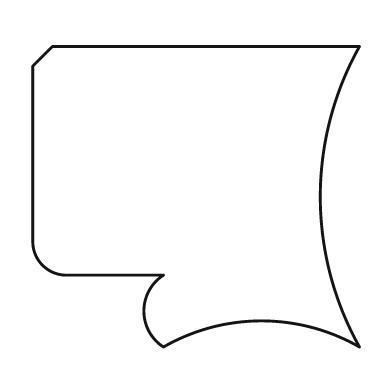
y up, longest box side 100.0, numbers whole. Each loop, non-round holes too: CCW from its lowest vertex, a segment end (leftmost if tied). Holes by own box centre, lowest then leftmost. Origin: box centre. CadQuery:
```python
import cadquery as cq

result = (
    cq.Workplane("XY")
    .moveTo(-10.0, -46.0)
    .threePointArc((20.0, -38.0), (50.0, -46.0))
    .threePointArc((38.0, 0.0), (50.0, 46.0))
    .lineTo(-44.0, 46.0)
    .lineTo(-50.0, 40.0)
    .lineTo(-50.0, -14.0)
    .threePointArc((-47.0, -21.0), (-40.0, -24.0))
    .lineTo(-10.0, -24.0)
    .threePointArc((-16.0, -35.0), (-10.0, -46.0))
    .close()
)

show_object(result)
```